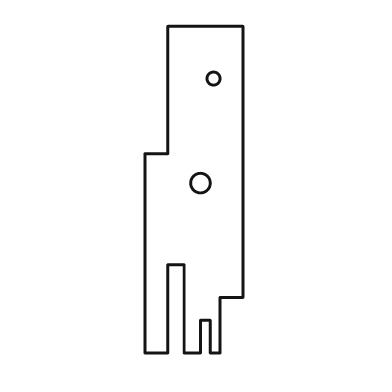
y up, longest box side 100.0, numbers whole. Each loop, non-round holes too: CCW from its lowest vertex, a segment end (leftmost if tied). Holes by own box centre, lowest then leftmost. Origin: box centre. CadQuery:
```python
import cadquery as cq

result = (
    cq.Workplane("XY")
    .moveTo(-15.0, -50.0)
    .lineTo(-8.0, -50.0)
    .lineTo(-8.0, -23.0)
    .lineTo(-3.0, -23.0)
    .lineTo(-3.0, -50.0)
    .lineTo(2.0, -50.0)
    .lineTo(2.0, -40.0)
    .lineTo(5.0, -40.0)
    .lineTo(5.0, -50.0)
    .lineTo(8.0, -50.0)
    .lineTo(8.0, -33.0)
    .lineTo(15.0, -33.0)
    .lineTo(15.0, 50.0)
    .lineTo(-8.0, 50.0)
    .lineTo(-8.0, 11.0)
    .lineTo(-15.0, 11.0)
    .close()
    .moveTo(2.0, 2.0)
    .circle(3.0)
    .moveTo(6.0, 34.0)
    .circle(2.0)
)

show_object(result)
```